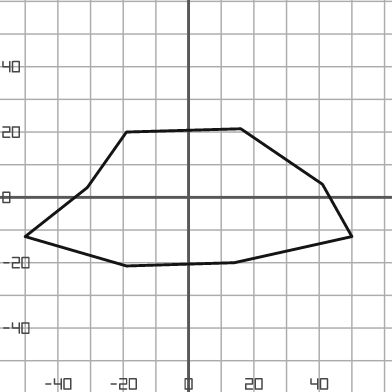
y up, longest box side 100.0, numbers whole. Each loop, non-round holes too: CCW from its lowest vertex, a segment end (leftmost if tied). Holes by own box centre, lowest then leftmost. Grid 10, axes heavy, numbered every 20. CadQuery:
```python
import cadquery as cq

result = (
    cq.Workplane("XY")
    .moveTo(-19.0, -21.0)
    .lineTo(14.0, -20.0)
    .lineTo(50.0, -12.0)
    .lineTo(41.0, 4.0)
    .lineTo(16.0, 21.0)
    .lineTo(-19.0, 20.0)
    .lineTo(-31.0, 3.0)
    .lineTo(-50.0, -12.0)
    .close()
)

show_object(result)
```